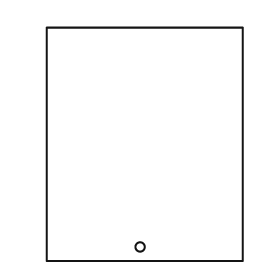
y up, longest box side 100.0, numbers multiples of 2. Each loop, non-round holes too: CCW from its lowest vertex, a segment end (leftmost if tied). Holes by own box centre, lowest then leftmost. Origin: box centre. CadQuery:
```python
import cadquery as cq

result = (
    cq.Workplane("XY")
    .moveTo(-42.0, -50.0)
    .lineTo(42.0, -50.0)
    .lineTo(42.0, 50.0)
    .lineTo(-42.0, 50.0)
    .close()
    .moveTo(-2.0, -44.0)
    .circle(2.0)
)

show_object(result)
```